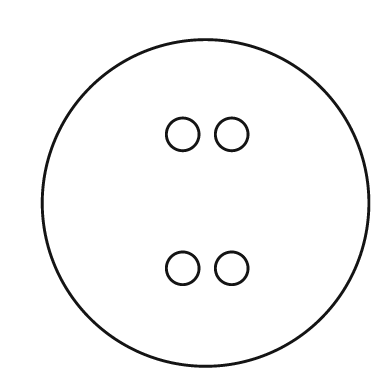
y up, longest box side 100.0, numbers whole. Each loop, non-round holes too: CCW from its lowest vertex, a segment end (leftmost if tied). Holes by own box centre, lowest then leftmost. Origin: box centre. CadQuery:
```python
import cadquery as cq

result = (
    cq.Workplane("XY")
    .moveTo(0.0, 0.0)
    .circle(50.0)
    .moveTo(-7.0, -20.0)
    .circle(5.0)
    .moveTo(8.0, -20.0)
    .circle(5.0)
    .moveTo(-7.0, 21.0)
    .circle(5.0)
    .moveTo(8.0, 21.0)
    .circle(5.0)
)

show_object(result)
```